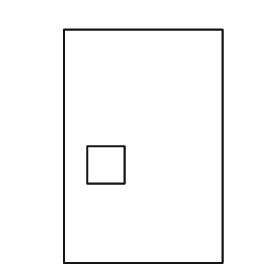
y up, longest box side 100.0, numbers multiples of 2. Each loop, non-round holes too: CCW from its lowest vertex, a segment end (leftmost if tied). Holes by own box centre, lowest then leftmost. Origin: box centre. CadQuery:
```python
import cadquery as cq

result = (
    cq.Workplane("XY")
    .moveTo(-34.0, -50.0)
    .lineTo(34.0, -50.0)
    .lineTo(34.0, 50.0)
    .lineTo(-34.0, 50.0)
    .close()
    .moveTo(-24.0, -16.0)
    .lineTo(-8.0, -16.0)
    .lineTo(-8.0, 0.0)
    .lineTo(-24.0, 0.0)
    .close()
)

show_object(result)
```